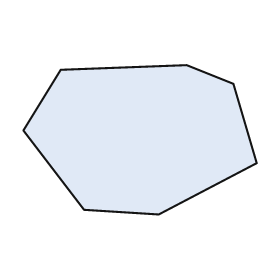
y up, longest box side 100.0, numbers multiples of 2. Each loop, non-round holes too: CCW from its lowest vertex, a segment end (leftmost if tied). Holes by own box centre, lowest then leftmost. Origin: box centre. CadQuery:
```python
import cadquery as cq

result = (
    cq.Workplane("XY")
    .moveTo(8.0, -32.0)
    .lineTo(50.0, -10.0)
    .lineTo(40.0, 24.0)
    .lineTo(20.0, 32.0)
    .lineTo(-34.0, 30.0)
    .lineTo(-50.0, 4.0)
    .lineTo(-24.0, -30.0)
    .close()
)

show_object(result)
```